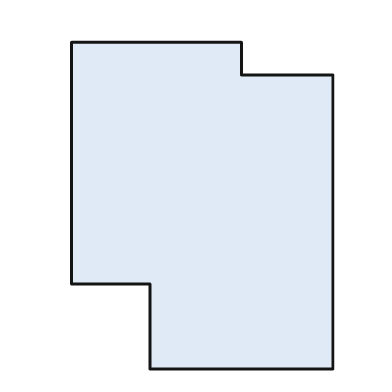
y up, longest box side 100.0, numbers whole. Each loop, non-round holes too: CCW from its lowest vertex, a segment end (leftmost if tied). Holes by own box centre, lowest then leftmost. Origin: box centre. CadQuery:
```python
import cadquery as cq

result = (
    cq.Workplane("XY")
    .moveTo(-16.0, -50.0)
    .lineTo(40.0, -50.0)
    .lineTo(40.0, 40.0)
    .lineTo(12.0, 40.0)
    .lineTo(12.0, 50.0)
    .lineTo(-40.0, 50.0)
    .lineTo(-40.0, -24.0)
    .lineTo(-16.0, -24.0)
    .close()
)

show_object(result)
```